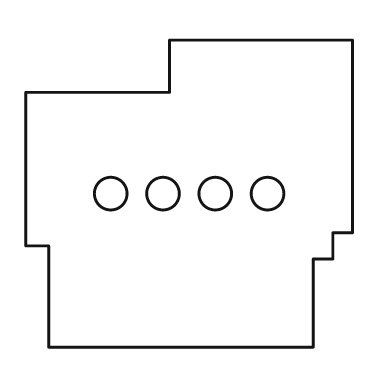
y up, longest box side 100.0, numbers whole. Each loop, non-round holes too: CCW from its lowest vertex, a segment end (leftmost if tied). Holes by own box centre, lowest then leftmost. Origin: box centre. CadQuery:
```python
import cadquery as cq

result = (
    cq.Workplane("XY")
    .moveTo(-43.0, -47.0)
    .lineTo(38.0, -47.0)
    .lineTo(38.0, -20.0)
    .lineTo(44.0, -20.0)
    .lineTo(44.0, -12.0)
    .lineTo(50.0, -12.0)
    .lineTo(50.0, 47.0)
    .lineTo(-6.0, 47.0)
    .lineTo(-6.0, 31.0)
    .lineTo(-50.0, 31.0)
    .lineTo(-50.0, -16.0)
    .lineTo(-43.0, -16.0)
    .close()
    .moveTo(-24.0, 0.0)
    .circle(5.0)
    .moveTo(-8.0, 0.0)
    .circle(5.0)
    .moveTo(8.0, 0.0)
    .circle(5.0)
    .moveTo(24.0, 0.0)
    .circle(5.0)
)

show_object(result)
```